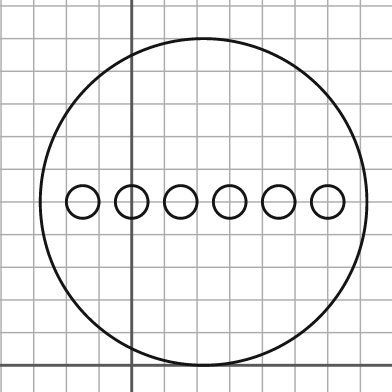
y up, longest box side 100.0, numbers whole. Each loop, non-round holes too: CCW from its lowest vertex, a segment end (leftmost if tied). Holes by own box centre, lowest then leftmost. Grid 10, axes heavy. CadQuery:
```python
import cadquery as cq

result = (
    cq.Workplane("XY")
    .moveTo(22.0, 50.0)
    .circle(50.0)
    .moveTo(-15.0, 50.0)
    .circle(5.0)
    .moveTo(0.0, 50.0)
    .circle(5.0)
    .moveTo(15.0, 50.0)
    .circle(5.0)
    .moveTo(30.0, 50.0)
    .circle(5.0)
    .moveTo(45.0, 50.0)
    .circle(5.0)
    .moveTo(60.0, 50.0)
    .circle(5.0)
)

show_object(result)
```